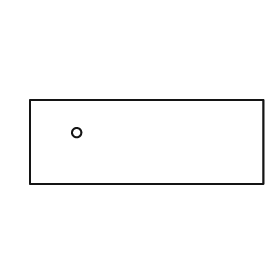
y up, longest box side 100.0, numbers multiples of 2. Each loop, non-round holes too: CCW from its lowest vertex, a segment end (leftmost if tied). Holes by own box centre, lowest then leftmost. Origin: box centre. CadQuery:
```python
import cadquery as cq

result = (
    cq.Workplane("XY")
    .moveTo(-50.0, -18.0)
    .lineTo(50.0, -18.0)
    .lineTo(50.0, 18.0)
    .lineTo(-50.0, 18.0)
    .close()
    .moveTo(-30.0, 4.0)
    .circle(2.0)
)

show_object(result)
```